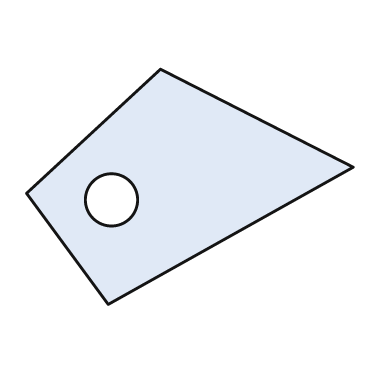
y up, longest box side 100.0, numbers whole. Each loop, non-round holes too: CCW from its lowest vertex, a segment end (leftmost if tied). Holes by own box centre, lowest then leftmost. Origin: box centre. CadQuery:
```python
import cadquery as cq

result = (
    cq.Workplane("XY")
    .moveTo(-25.0, -36.0)
    .lineTo(50.0, 6.0)
    .lineTo(-9.0, 36.0)
    .lineTo(-50.0, -2.0)
    .close()
    .moveTo(-24.0, -4.0)
    .circle(8.0)
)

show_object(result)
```